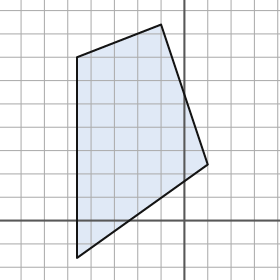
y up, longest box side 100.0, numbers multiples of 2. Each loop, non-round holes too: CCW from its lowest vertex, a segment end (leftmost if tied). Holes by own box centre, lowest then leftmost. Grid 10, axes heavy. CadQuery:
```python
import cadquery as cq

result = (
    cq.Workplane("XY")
    .moveTo(-46.0, -16.0)
    .lineTo(10.0, 24.0)
    .lineTo(-10.0, 84.0)
    .lineTo(-46.0, 70.0)
    .close()
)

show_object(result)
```